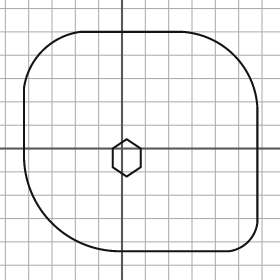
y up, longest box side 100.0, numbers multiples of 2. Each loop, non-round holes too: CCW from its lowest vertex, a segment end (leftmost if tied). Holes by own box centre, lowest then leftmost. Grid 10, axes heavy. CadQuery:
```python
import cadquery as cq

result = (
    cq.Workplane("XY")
    .moveTo(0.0, -44.0)
    .lineTo(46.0, -44.0)
    .threePointArc((54.0, -40.0), (58.0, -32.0))
    .lineTo(58.0, 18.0)
    .threePointArc((48.0, 40.0), (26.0, 50.0))
    .lineTo(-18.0, 50.0)
    .threePointArc((-34.0, 42.0), (-42.0, 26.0))
    .lineTo(-42.0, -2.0)
    .threePointArc((-30.0, -32.0), (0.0, -44.0))
    .close()
    .moveTo(2.0, -12.0)
    .lineTo(8.0, -8.0)
    .lineTo(8.0, 0.0)
    .lineTo(2.0, 4.0)
    .lineTo(-4.0, 0.0)
    .lineTo(-4.0, -8.0)
    .close()
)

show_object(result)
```